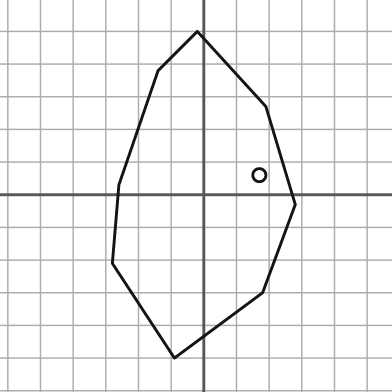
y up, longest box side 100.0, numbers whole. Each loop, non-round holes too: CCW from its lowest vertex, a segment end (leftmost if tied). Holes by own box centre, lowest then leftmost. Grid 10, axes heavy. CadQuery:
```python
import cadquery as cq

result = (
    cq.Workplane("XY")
    .moveTo(-9.0, -50.0)
    .lineTo(18.0, -30.0)
    .lineTo(28.0, -3.0)
    .lineTo(19.0, 27.0)
    .lineTo(-2.0, 50.0)
    .lineTo(-14.0, 38.0)
    .lineTo(-26.0, 3.0)
    .lineTo(-28.0, -21.0)
    .close()
    .moveTo(17.0, 6.0)
    .circle(2.0)
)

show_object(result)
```